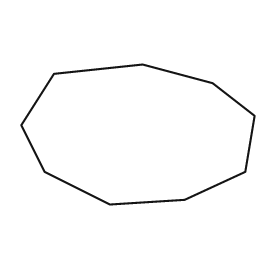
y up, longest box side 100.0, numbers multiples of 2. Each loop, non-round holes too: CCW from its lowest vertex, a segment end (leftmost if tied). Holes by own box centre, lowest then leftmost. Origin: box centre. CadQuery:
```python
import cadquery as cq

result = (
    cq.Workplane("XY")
    .moveTo(-12.0, -30.0)
    .lineTo(20.0, -28.0)
    .lineTo(46.0, -16.0)
    .lineTo(50.0, 8.0)
    .lineTo(32.0, 22.0)
    .lineTo(2.0, 30.0)
    .lineTo(-36.0, 26.0)
    .lineTo(-50.0, 4.0)
    .lineTo(-40.0, -16.0)
    .close()
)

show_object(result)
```